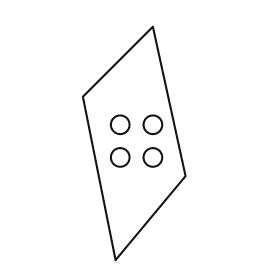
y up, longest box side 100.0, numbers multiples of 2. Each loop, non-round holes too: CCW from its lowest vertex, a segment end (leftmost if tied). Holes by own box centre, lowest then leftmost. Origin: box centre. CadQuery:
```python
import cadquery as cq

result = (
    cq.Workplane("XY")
    .moveTo(-8.0, -50.0)
    .lineTo(22.0, -14.0)
    .lineTo(8.0, 50.0)
    .lineTo(-22.0, 20.0)
    .close()
    .moveTo(-6.0, -6.0)
    .circle(4.0)
    .moveTo(8.0, -6.0)
    .circle(4.0)
    .moveTo(-6.0, 8.0)
    .circle(4.0)
    .moveTo(8.0, 8.0)
    .circle(4.0)
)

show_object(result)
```